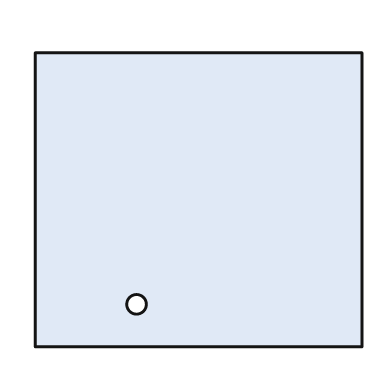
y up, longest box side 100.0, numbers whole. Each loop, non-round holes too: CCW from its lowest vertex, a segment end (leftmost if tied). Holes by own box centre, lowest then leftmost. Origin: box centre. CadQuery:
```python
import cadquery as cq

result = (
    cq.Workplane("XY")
    .moveTo(-50.0, -45.0)
    .lineTo(50.0, -45.0)
    .lineTo(50.0, 45.0)
    .lineTo(-50.0, 45.0)
    .close()
    .moveTo(-19.0, -32.0)
    .circle(3.0)
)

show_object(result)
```